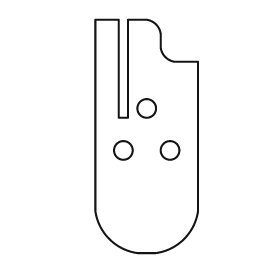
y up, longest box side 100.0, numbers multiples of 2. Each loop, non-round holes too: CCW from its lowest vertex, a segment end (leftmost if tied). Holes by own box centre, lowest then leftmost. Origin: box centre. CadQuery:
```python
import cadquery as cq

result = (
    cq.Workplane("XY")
    .moveTo(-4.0, -50.0)
    .lineTo(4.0, -50.0)
    .threePointArc((16.0, -44.0), (22.0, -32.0))
    .lineTo(22.0, 32.0)
    .lineTo(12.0, 32.0)
    .threePointArc((8.0, 34.0), (6.0, 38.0))
    .lineTo(6.0, 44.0)
    .threePointArc((4.0, 48.0), (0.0, 50.0))
    .lineTo(-8.0, 50.0)
    .lineTo(-8.0, 8.0)
    .lineTo(-12.0, 8.0)
    .lineTo(-12.0, 50.0)
    .lineTo(-22.0, 50.0)
    .lineTo(-22.0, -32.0)
    .threePointArc((-16.0, -44.0), (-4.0, -50.0))
    .close()
    .moveTo(-10.0, -6.0)
    .circle(4.0)
    .moveTo(10.0, -6.0)
    .circle(4.0)
    .moveTo(0.0, 12.0)
    .circle(4.0)
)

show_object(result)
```